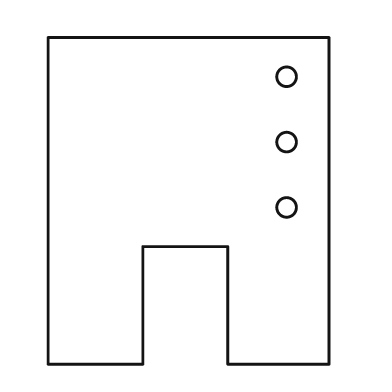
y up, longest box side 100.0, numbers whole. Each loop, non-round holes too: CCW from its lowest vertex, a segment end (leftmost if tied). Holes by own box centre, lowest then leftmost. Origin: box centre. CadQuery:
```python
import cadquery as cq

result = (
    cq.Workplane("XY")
    .moveTo(-43.0, -50.0)
    .lineTo(-14.0, -50.0)
    .lineTo(-14.0, -14.0)
    .lineTo(12.0, -14.0)
    .lineTo(12.0, -50.0)
    .lineTo(43.0, -50.0)
    .lineTo(43.0, 50.0)
    .lineTo(-43.0, 50.0)
    .close()
    .moveTo(30.0, -2.0)
    .circle(3.0)
    .moveTo(30.0, 18.0)
    .circle(3.0)
    .moveTo(30.0, 38.0)
    .circle(3.0)
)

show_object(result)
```